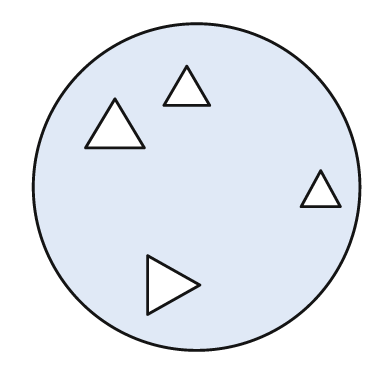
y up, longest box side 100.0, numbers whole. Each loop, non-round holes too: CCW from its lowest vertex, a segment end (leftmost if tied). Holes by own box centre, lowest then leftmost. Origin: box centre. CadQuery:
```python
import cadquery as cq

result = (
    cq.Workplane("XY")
    .moveTo(0.0, 0.0)
    .circle(50.0)
    .moveTo(-15.0, -39.0)
    .lineTo(1.0, -30.0)
    .lineTo(-15.0, -21.0)
    .close()
    .moveTo(32.0, -6.0)
    .lineTo(44.0, -6.0)
    .lineTo(38.0, 5.0)
    .close()
    .moveTo(-34.0, 12.0)
    .lineTo(-16.0, 12.0)
    .lineTo(-25.0, 27.0)
    .close()
    .moveTo(-10.0, 25.0)
    .lineTo(4.0, 25.0)
    .lineTo(-3.0, 37.0)
    .close()
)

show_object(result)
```